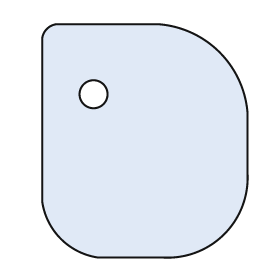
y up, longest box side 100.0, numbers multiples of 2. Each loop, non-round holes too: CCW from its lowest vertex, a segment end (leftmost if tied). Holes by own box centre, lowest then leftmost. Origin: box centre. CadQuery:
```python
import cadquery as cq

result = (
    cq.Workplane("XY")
    .moveTo(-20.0, -50.0)
    .lineTo(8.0, -50.0)
    .threePointArc((34.0, -40.0), (44.0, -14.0))
    .lineTo(44.0, 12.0)
    .threePointArc((32.0, 38.0), (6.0, 50.0))
    .lineTo(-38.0, 50.0)
    .threePointArc((-42.0, 48.0), (-44.0, 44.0))
    .lineTo(-44.0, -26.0)
    .threePointArc((-36.0, -42.0), (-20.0, -50.0))
    .close()
    .moveTo(-22.0, 20.0)
    .circle(6.0)
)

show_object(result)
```